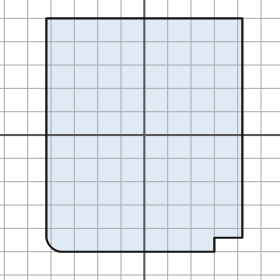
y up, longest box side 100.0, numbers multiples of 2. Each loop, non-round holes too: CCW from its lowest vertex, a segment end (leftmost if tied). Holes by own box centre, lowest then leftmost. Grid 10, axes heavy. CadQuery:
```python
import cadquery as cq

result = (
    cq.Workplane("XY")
    .moveTo(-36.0, -50.0)
    .lineTo(30.0, -50.0)
    .lineTo(30.0, -44.0)
    .lineTo(42.0, -44.0)
    .lineTo(42.0, 50.0)
    .lineTo(-42.0, 50.0)
    .lineTo(-42.0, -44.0)
    .threePointArc((-40.0, -48.0), (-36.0, -50.0))
    .close()
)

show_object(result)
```